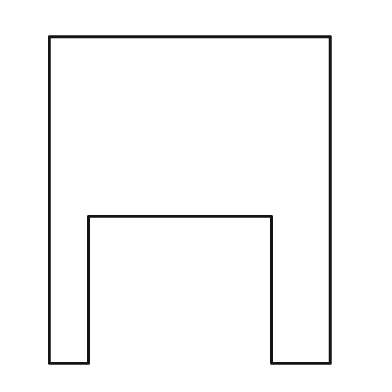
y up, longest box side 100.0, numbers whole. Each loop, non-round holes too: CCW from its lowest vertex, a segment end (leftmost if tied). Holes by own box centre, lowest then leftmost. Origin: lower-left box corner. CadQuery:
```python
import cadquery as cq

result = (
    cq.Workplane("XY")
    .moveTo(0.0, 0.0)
    .lineTo(12.0, 0.0)
    .lineTo(12.0, 45.0)
    .lineTo(68.0, 45.0)
    .lineTo(68.0, 0.0)
    .lineTo(86.0, 0.0)
    .lineTo(86.0, 100.0)
    .lineTo(0.0, 100.0)
    .close()
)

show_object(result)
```